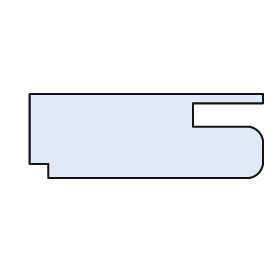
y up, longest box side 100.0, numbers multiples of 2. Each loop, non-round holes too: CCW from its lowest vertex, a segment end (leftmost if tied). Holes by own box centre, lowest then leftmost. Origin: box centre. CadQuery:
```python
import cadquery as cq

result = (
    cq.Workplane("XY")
    .moveTo(-42.0, -18.0)
    .lineTo(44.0, -18.0)
    .threePointArc((48.0, -16.0), (50.0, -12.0))
    .lineTo(50.0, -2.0)
    .threePointArc((48.0, 2.0), (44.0, 4.0))
    .lineTo(20.0, 4.0)
    .lineTo(20.0, 14.0)
    .lineTo(50.0, 14.0)
    .lineTo(50.0, 18.0)
    .lineTo(-50.0, 18.0)
    .lineTo(-50.0, -12.0)
    .lineTo(-42.0, -12.0)
    .close()
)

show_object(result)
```